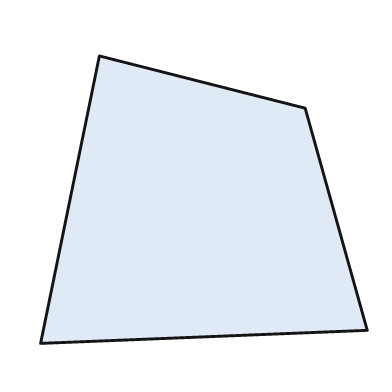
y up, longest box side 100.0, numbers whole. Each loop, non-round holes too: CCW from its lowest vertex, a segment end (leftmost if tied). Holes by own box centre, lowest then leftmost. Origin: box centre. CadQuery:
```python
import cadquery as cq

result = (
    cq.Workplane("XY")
    .moveTo(-50.0, -44.0)
    .lineTo(50.0, -40.0)
    .lineTo(31.0, 28.0)
    .lineTo(-32.0, 44.0)
    .close()
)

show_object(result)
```